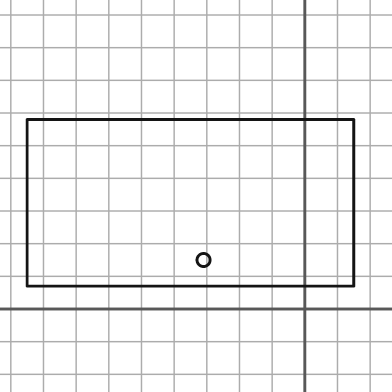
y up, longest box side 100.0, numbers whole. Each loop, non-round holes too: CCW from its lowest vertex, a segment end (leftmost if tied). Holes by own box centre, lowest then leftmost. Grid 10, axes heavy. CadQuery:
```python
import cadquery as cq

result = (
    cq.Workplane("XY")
    .moveTo(-85.0, 7.0)
    .lineTo(15.0, 7.0)
    .lineTo(15.0, 58.0)
    .lineTo(-85.0, 58.0)
    .close()
    .moveTo(-31.0, 15.0)
    .circle(2.0)
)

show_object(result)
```